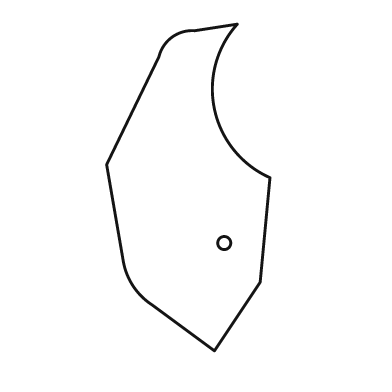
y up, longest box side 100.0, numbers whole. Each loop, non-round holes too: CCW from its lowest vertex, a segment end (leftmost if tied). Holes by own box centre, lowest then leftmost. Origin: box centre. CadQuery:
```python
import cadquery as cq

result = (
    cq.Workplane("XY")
    .moveTo(8.0, -50.0)
    .lineTo(22.0, -29.0)
    .lineTo(25.0, 3.0)
    .threePointArc((8.0, 24.0), (15.0, 50.0))
    .lineTo(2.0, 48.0)
    .threePointArc((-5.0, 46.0), (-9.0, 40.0))
    .lineTo(-25.0, 7.0)
    .lineTo(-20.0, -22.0)
    .threePointArc((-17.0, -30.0), (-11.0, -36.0))
    .close()
    .moveTo(11.0, -17.0)
    .circle(2.0)
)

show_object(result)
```